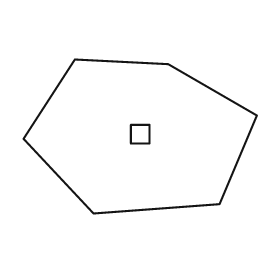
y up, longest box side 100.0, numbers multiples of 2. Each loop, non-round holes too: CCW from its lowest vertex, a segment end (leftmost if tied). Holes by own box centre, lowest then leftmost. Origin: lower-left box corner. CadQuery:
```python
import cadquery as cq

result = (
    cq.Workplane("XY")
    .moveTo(30.0, 0.0)
    .lineTo(84.0, 4.0)
    .lineTo(100.0, 42.0)
    .lineTo(62.0, 64.0)
    .lineTo(22.0, 66.0)
    .lineTo(0.0, 32.0)
    .close()
    .moveTo(46.0, 30.0)
    .lineTo(54.0, 30.0)
    .lineTo(54.0, 38.0)
    .lineTo(46.0, 38.0)
    .close()
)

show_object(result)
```